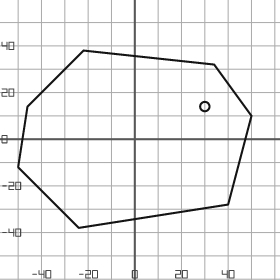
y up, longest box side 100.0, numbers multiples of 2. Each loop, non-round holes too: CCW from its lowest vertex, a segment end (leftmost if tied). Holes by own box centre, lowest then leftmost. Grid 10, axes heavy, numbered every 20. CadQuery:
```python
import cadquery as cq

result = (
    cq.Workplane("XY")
    .moveTo(-24.0, -38.0)
    .lineTo(40.0, -28.0)
    .lineTo(50.0, 10.0)
    .lineTo(34.0, 32.0)
    .lineTo(-22.0, 38.0)
    .lineTo(-46.0, 14.0)
    .lineTo(-50.0, -12.0)
    .close()
    .moveTo(30.0, 14.0)
    .circle(2.0)
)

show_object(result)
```